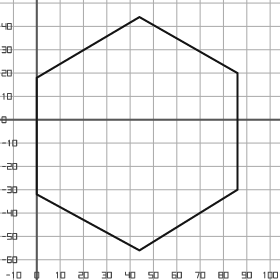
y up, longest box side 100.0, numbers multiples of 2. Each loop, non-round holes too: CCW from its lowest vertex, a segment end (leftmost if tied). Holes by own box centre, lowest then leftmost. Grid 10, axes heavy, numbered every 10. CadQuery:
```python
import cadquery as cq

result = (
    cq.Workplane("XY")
    .moveTo(44.0, -56.0)
    .lineTo(86.0, -30.0)
    .lineTo(86.0, 20.0)
    .lineTo(44.0, 44.0)
    .lineTo(0.0, 18.0)
    .lineTo(0.0, -32.0)
    .close()
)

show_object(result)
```